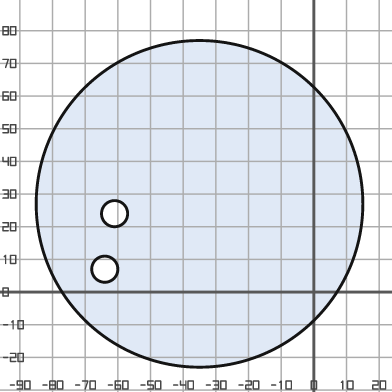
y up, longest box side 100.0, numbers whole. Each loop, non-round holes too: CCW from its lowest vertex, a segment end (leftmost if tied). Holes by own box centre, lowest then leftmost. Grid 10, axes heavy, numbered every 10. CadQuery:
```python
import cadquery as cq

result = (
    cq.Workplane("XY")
    .moveTo(-35.0, 27.0)
    .circle(50.0)
    .moveTo(-64.0, 7.0)
    .circle(4.0)
    .moveTo(-61.0, 24.0)
    .circle(4.0)
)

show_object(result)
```